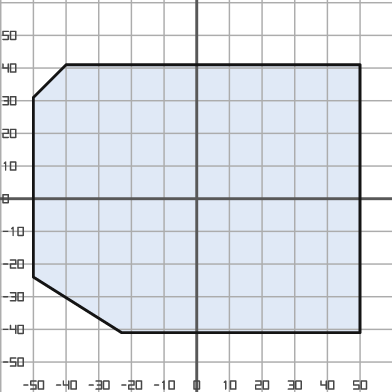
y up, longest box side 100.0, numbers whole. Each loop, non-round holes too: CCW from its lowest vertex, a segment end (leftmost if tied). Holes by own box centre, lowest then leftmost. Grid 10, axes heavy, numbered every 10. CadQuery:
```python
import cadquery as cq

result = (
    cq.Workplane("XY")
    .moveTo(-23.0, -41.0)
    .lineTo(50.0, -41.0)
    .lineTo(50.0, 41.0)
    .lineTo(-40.0, 41.0)
    .lineTo(-50.0, 31.0)
    .lineTo(-50.0, -24.0)
    .close()
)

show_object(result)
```